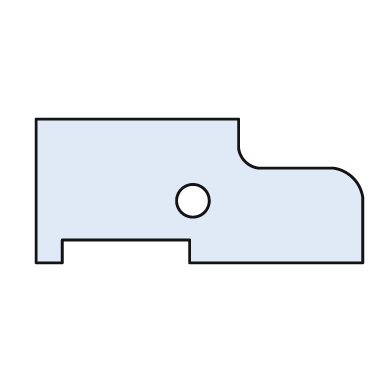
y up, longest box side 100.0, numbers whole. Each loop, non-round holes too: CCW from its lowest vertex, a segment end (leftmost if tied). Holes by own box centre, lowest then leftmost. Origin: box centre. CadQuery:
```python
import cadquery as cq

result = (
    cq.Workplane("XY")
    .moveTo(-50.0, -22.0)
    .lineTo(-42.0, -22.0)
    .lineTo(-42.0, -15.0)
    .lineTo(-3.0, -15.0)
    .lineTo(-3.0, -22.0)
    .lineTo(50.0, -22.0)
    .lineTo(50.0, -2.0)
    .threePointArc((47.0, 4.0), (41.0, 7.0))
    .lineTo(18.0, 7.0)
    .threePointArc((14.0, 9.0), (12.0, 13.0))
    .lineTo(12.0, 22.0)
    .lineTo(-50.0, 22.0)
    .close()
    .moveTo(-2.0, -3.0)
    .circle(5.0)
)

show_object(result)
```